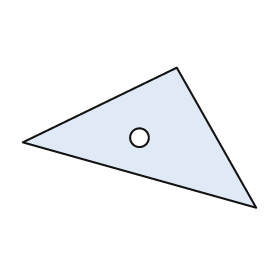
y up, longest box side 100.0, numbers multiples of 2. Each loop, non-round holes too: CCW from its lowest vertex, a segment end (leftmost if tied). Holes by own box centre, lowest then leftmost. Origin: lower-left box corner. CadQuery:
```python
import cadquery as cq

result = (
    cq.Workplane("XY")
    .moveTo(100.0, 0.0)
    .lineTo(66.0, 60.0)
    .lineTo(0.0, 28.0)
    .close()
    .moveTo(50.0, 30.0)
    .circle(4.0)
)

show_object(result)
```